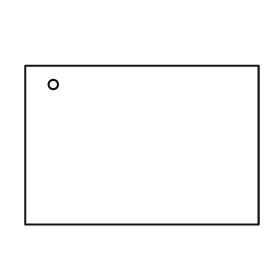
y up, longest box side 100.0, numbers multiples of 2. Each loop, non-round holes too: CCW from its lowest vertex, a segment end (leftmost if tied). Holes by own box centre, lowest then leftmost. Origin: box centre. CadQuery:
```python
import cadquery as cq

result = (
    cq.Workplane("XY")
    .moveTo(-50.0, -34.0)
    .lineTo(50.0, -34.0)
    .lineTo(50.0, 34.0)
    .lineTo(-50.0, 34.0)
    .close()
    .moveTo(-38.0, 26.0)
    .circle(2.0)
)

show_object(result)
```